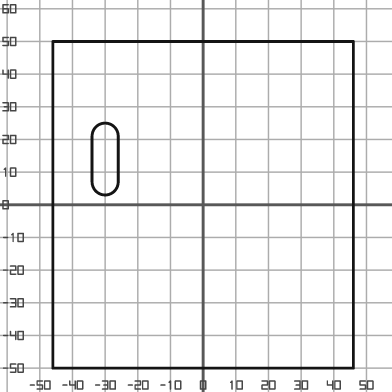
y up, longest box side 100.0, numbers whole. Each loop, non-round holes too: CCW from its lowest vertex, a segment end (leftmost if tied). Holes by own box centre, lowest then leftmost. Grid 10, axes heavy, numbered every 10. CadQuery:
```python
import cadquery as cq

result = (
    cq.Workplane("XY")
    .moveTo(-46.0, -50.0)
    .lineTo(46.0, -50.0)
    .lineTo(46.0, 50.0)
    .lineTo(-46.0, 50.0)
    .close()
    .moveTo(-34.0, 7.0)
    .threePointArc((-30.0, 3.0), (-26.0, 7.0))
    .lineTo(-26.0, 21.0)
    .threePointArc((-30.0, 25.0), (-34.0, 21.0))
    .close()
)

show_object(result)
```